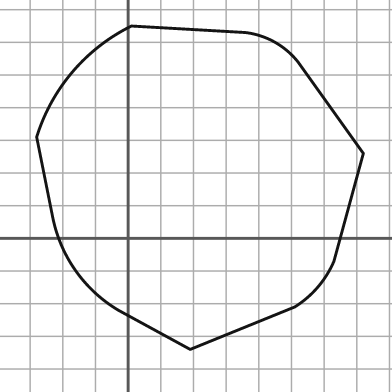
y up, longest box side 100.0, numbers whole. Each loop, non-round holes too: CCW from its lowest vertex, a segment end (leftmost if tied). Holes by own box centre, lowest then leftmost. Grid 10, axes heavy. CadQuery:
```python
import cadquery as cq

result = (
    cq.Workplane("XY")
    .moveTo(19.0, -34.0)
    .lineTo(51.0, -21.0)
    .threePointArc((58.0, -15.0), (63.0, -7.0))
    .lineTo(72.0, 26.0)
    .lineTo(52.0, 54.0)
    .threePointArc((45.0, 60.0), (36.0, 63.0))
    .lineTo(1.0, 65.0)
    .threePointArc((-17.0, 51.0), (-28.0, 31.0))
    .lineTo(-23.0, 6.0)
    .threePointArc((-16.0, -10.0), (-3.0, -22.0))
    .close()
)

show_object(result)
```